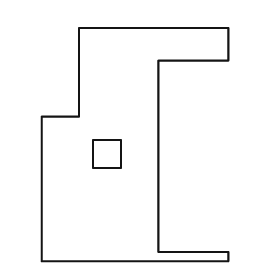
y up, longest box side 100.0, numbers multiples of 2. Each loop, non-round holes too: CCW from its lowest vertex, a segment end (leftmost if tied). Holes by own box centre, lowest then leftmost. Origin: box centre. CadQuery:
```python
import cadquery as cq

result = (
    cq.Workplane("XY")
    .moveTo(-40.0, -50.0)
    .lineTo(40.0, -50.0)
    .lineTo(40.0, -46.0)
    .lineTo(10.0, -46.0)
    .lineTo(10.0, 36.0)
    .lineTo(40.0, 36.0)
    .lineTo(40.0, 50.0)
    .lineTo(-24.0, 50.0)
    .lineTo(-24.0, 12.0)
    .lineTo(-40.0, 12.0)
    .close()
    .moveTo(-18.0, -10.0)
    .lineTo(-6.0, -10.0)
    .lineTo(-6.0, 2.0)
    .lineTo(-18.0, 2.0)
    .close()
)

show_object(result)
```